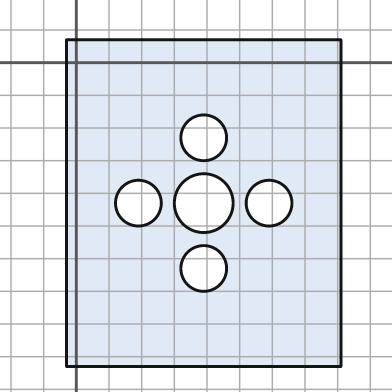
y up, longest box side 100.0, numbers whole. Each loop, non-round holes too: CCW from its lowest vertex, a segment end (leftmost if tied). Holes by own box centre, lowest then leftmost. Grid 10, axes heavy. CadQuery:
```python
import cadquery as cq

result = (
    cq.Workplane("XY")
    .moveTo(-3.0, -93.0)
    .lineTo(81.0, -93.0)
    .lineTo(81.0, 7.0)
    .lineTo(-3.0, 7.0)
    .close()
    .moveTo(39.0, -63.0)
    .circle(7.0)
    .moveTo(19.0, -43.0)
    .circle(7.0)
    .moveTo(39.0, -43.0)
    .circle(9.0)
    .moveTo(59.0, -43.0)
    .circle(7.0)
    .moveTo(39.0, -23.0)
    .circle(7.0)
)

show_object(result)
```